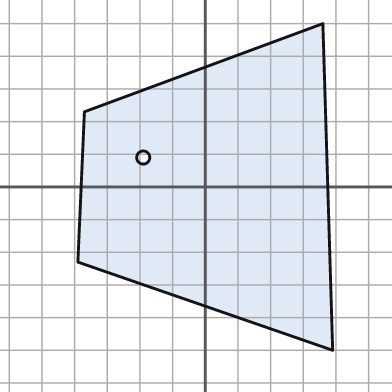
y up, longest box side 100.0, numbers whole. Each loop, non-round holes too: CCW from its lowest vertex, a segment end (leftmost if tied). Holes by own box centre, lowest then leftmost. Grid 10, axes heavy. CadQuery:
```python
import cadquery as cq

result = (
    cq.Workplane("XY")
    .moveTo(39.0, -50.0)
    .lineTo(36.0, 50.0)
    .lineTo(-37.0, 23.0)
    .lineTo(-39.0, -23.0)
    .close()
    .moveTo(-19.0, 9.0)
    .circle(2.0)
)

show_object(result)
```